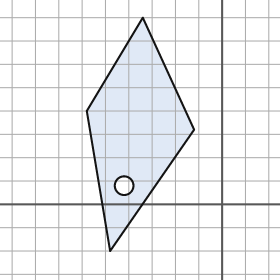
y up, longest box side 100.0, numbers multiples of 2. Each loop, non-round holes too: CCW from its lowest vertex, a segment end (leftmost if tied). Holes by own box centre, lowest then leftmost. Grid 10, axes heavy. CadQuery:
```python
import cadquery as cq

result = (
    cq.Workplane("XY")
    .moveTo(-48.0, -20.0)
    .lineTo(-12.0, 32.0)
    .lineTo(-34.0, 80.0)
    .lineTo(-58.0, 40.0)
    .close()
    .moveTo(-42.0, 8.0)
    .circle(4.0)
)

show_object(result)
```